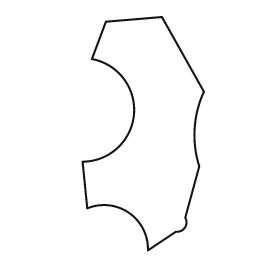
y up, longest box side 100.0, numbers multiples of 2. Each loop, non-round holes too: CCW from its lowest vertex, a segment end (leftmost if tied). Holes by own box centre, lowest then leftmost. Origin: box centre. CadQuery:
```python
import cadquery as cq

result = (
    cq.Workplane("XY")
    .moveTo(2.0, -50.0)
    .lineTo(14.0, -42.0)
    .threePointArc((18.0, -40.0), (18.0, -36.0))
    .lineTo(24.0, -14.0)
    .threePointArc((22.0, 2.0), (26.0, 18.0))
    .lineTo(8.0, 50.0)
    .lineTo(-16.0, 48.0)
    .lineTo(-22.0, 32.0)
    .threePointArc((-4.0, 8.0), (-26.0, -12.0))
    .lineTo(-24.0, -32.0)
    .threePointArc((-6.0, -34.0), (2.0, -50.0))
    .close()
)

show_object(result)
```